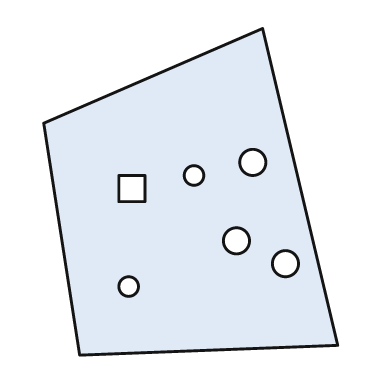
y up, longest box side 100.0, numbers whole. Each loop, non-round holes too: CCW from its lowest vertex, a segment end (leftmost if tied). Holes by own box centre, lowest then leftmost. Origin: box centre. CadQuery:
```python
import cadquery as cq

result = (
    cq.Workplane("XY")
    .moveTo(-34.0, -50.0)
    .lineTo(45.0, -47.0)
    .lineTo(22.0, 50.0)
    .lineTo(-45.0, 21.0)
    .close()
    .moveTo(-19.0, -29.0)
    .circle(3.0)
    .moveTo(29.0, -22.0)
    .circle(4.0)
    .moveTo(14.0, -15.0)
    .circle(4.0)
    .moveTo(-22.0, -3.0)
    .lineTo(-14.0, -3.0)
    .lineTo(-14.0, 5.0)
    .lineTo(-22.0, 5.0)
    .close()
    .moveTo(1.0, 5.0)
    .circle(3.0)
    .moveTo(19.0, 9.0)
    .circle(4.0)
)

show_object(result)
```